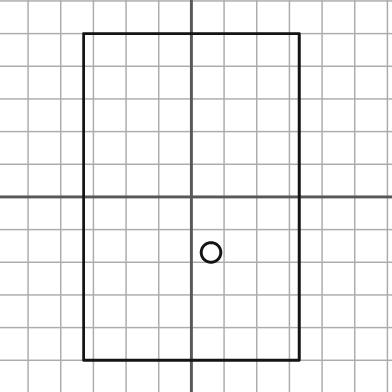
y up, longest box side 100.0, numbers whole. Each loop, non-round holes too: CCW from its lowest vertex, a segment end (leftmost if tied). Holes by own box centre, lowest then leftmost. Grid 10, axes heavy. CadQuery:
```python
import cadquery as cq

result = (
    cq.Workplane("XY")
    .moveTo(-33.0, -50.0)
    .lineTo(33.0, -50.0)
    .lineTo(33.0, 50.0)
    .lineTo(-33.0, 50.0)
    .close()
    .moveTo(6.0, -17.0)
    .circle(3.0)
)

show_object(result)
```